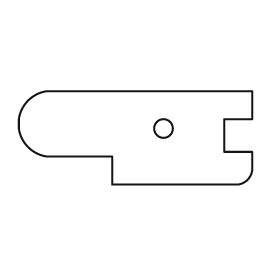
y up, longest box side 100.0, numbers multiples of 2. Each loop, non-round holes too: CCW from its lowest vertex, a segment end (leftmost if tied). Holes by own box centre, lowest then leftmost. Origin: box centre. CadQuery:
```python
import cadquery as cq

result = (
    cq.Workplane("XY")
    .moveTo(-10.0, -20.0)
    .lineTo(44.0, -20.0)
    .threePointArc((48.0, -18.0), (50.0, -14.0))
    .lineTo(50.0, -6.0)
    .lineTo(38.0, -6.0)
    .lineTo(38.0, 8.0)
    .lineTo(50.0, 8.0)
    .lineTo(50.0, 20.0)
    .lineTo(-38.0, 20.0)
    .threePointArc((-46.0, 16.0), (-50.0, 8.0))
    .lineTo(-50.0, 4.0)
    .threePointArc((-46.0, -4.0), (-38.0, -8.0))
    .lineTo(-10.0, -8.0)
    .close()
    .moveTo(12.0, 4.0)
    .circle(4.0)
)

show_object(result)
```